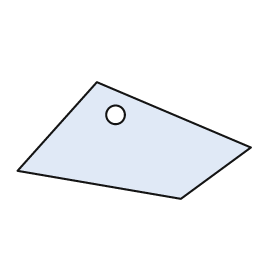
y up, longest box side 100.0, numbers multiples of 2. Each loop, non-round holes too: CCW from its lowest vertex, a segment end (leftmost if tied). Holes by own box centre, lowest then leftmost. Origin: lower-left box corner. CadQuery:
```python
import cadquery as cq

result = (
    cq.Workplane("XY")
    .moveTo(70.0, 0.0)
    .lineTo(100.0, 22.0)
    .lineTo(34.0, 50.0)
    .lineTo(0.0, 12.0)
    .close()
    .moveTo(42.0, 36.0)
    .circle(4.0)
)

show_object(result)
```